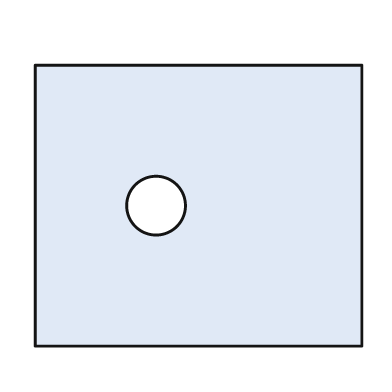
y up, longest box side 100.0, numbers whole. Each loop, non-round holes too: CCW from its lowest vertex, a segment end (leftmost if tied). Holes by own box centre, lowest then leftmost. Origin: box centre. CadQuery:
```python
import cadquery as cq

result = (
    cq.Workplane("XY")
    .moveTo(-50.0, -43.0)
    .lineTo(50.0, -43.0)
    .lineTo(50.0, 43.0)
    .lineTo(-50.0, 43.0)
    .close()
    .moveTo(-13.0, 0.0)
    .circle(9.0)
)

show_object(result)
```